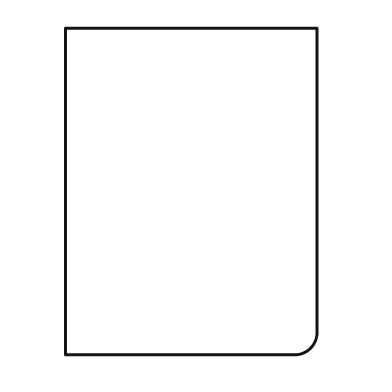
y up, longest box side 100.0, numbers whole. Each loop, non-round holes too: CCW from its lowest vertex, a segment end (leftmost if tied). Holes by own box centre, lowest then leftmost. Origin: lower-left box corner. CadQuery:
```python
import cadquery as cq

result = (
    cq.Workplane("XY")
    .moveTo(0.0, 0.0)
    .lineTo(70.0, 0.0)
    .threePointArc((75.0, 2.0), (77.0, 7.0))
    .lineTo(77.0, 100.0)
    .lineTo(0.0, 100.0)
    .close()
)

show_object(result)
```